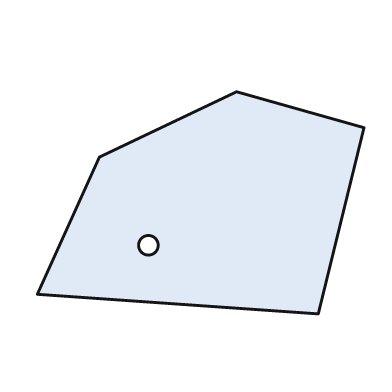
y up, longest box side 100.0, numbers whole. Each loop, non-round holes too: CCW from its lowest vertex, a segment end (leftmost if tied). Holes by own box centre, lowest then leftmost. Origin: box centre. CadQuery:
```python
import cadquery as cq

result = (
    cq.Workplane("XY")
    .moveTo(36.0, -34.0)
    .lineTo(50.0, 23.0)
    .lineTo(11.0, 34.0)
    .lineTo(-31.0, 14.0)
    .lineTo(-50.0, -28.0)
    .close()
    .moveTo(-16.0, -13.0)
    .circle(3.0)
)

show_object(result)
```